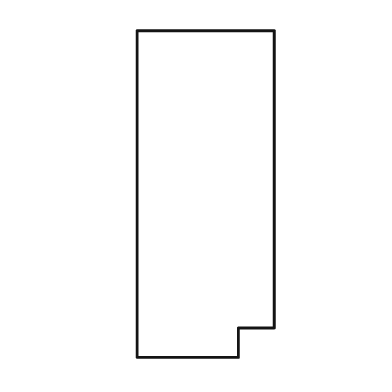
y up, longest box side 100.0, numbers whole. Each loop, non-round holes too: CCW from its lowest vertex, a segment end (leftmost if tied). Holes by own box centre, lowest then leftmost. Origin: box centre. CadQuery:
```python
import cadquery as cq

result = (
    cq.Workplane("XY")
    .moveTo(-21.0, -50.0)
    .lineTo(10.0, -50.0)
    .lineTo(10.0, -41.0)
    .lineTo(21.0, -41.0)
    .lineTo(21.0, 50.0)
    .lineTo(-21.0, 50.0)
    .close()
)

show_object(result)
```